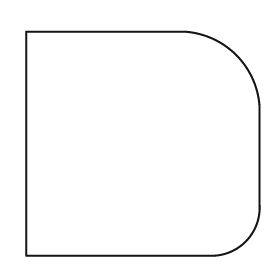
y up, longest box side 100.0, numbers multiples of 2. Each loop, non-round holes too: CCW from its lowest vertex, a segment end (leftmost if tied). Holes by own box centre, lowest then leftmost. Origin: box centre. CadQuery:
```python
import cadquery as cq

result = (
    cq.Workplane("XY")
    .moveTo(-50.0, -48.0)
    .lineTo(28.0, -48.0)
    .threePointArc((44.0, -42.0), (50.0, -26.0))
    .lineTo(50.0, 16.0)
    .threePointArc((40.0, 38.0), (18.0, 48.0))
    .lineTo(-50.0, 48.0)
    .close()
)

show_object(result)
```